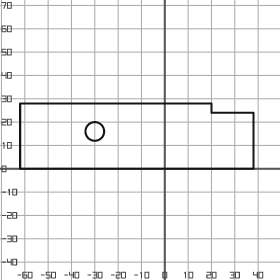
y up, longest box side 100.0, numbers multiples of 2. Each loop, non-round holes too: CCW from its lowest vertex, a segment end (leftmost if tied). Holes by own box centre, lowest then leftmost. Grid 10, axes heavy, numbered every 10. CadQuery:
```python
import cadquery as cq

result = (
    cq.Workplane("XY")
    .moveTo(-62.0, 0.0)
    .lineTo(38.0, 0.0)
    .lineTo(38.0, 24.0)
    .lineTo(20.0, 24.0)
    .lineTo(20.0, 28.0)
    .lineTo(-62.0, 28.0)
    .close()
    .moveTo(-30.0, 16.0)
    .circle(4.0)
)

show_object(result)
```